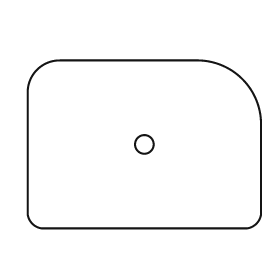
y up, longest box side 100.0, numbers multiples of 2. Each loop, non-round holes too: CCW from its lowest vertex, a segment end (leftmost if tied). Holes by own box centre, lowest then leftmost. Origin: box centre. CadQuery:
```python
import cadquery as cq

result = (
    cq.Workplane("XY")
    .moveTo(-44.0, -36.0)
    .lineTo(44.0, -36.0)
    .threePointArc((48.0, -34.0), (50.0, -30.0))
    .lineTo(50.0, 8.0)
    .threePointArc((42.0, 28.0), (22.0, 36.0))
    .lineTo(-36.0, 36.0)
    .threePointArc((-46.0, 32.0), (-50.0, 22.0))
    .lineTo(-50.0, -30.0)
    .threePointArc((-48.0, -34.0), (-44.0, -36.0))
    .close()
    .moveTo(0.0, 0.0)
    .circle(4.0)
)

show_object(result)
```